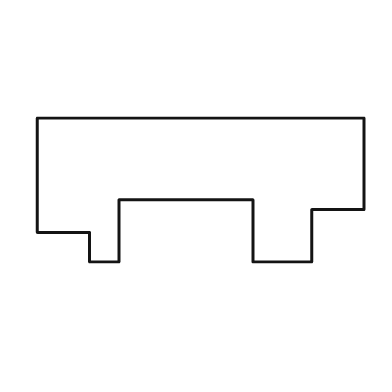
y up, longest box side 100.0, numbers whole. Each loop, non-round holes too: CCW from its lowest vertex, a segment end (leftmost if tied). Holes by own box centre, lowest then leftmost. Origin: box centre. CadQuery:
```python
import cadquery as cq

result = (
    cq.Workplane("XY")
    .moveTo(-34.0, -22.0)
    .lineTo(-25.0, -22.0)
    .lineTo(-25.0, -3.0)
    .lineTo(16.0, -3.0)
    .lineTo(16.0, -22.0)
    .lineTo(34.0, -22.0)
    .lineTo(34.0, -6.0)
    .lineTo(50.0, -6.0)
    .lineTo(50.0, 22.0)
    .lineTo(-50.0, 22.0)
    .lineTo(-50.0, -13.0)
    .lineTo(-34.0, -13.0)
    .close()
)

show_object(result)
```